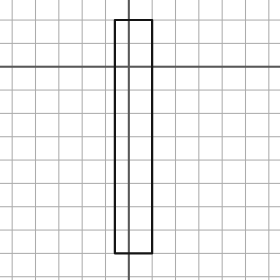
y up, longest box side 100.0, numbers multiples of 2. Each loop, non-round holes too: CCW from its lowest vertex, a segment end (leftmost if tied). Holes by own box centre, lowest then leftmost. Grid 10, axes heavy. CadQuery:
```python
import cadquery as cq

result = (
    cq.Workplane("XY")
    .moveTo(-6.0, -80.0)
    .lineTo(10.0, -80.0)
    .lineTo(10.0, 20.0)
    .lineTo(-6.0, 20.0)
    .close()
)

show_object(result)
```